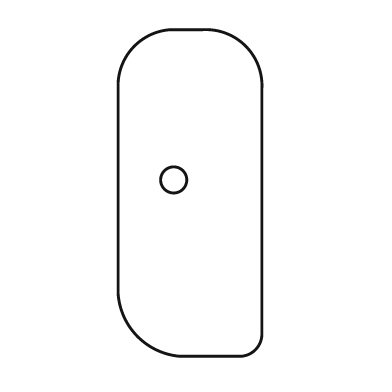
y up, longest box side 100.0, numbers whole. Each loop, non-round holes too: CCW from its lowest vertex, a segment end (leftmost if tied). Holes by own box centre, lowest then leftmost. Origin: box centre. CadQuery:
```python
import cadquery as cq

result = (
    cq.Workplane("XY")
    .moveTo(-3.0, -50.0)
    .lineTo(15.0, -50.0)
    .threePointArc((20.0, -48.0), (22.0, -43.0))
    .lineTo(22.0, 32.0)
    .threePointArc((17.0, 45.0), (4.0, 50.0))
    .lineTo(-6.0, 50.0)
    .threePointArc((-17.0, 45.0), (-22.0, 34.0))
    .lineTo(-22.0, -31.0)
    .threePointArc((-16.0, -44.0), (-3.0, -50.0))
    .close()
    .moveTo(-5.0, 4.0)
    .circle(4.0)
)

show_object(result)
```